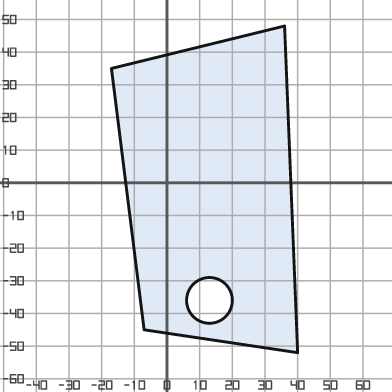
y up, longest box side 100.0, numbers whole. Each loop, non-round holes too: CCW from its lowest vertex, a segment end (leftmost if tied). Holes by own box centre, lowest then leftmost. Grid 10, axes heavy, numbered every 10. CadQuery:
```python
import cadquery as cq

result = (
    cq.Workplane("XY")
    .moveTo(40.0, -52.0)
    .lineTo(36.0, 48.0)
    .lineTo(-17.0, 35.0)
    .lineTo(-7.0, -45.0)
    .close()
    .moveTo(13.0, -36.0)
    .circle(7.0)
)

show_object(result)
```